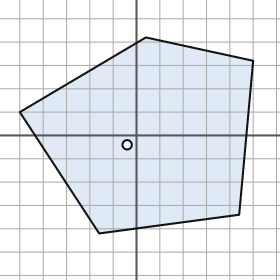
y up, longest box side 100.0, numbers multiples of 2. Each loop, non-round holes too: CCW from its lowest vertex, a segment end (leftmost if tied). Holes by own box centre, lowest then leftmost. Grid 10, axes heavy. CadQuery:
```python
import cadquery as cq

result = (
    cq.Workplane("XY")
    .moveTo(-16.0, -42.0)
    .lineTo(44.0, -34.0)
    .lineTo(50.0, 32.0)
    .lineTo(4.0, 42.0)
    .lineTo(-50.0, 10.0)
    .close()
    .moveTo(-4.0, -4.0)
    .circle(2.0)
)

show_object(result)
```